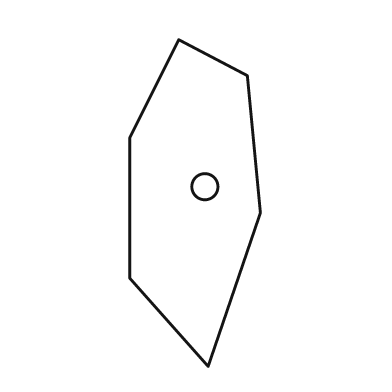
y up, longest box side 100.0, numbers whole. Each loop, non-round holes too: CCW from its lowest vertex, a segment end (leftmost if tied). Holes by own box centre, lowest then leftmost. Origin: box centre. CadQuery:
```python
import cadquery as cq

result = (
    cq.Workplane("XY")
    .moveTo(4.0, -50.0)
    .lineTo(20.0, -3.0)
    .lineTo(16.0, 39.0)
    .lineTo(-5.0, 50.0)
    .lineTo(-20.0, 20.0)
    .lineTo(-20.0, -23.0)
    .close()
    .moveTo(3.0, 5.0)
    .circle(4.0)
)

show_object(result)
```